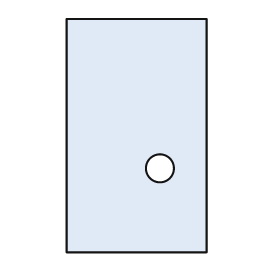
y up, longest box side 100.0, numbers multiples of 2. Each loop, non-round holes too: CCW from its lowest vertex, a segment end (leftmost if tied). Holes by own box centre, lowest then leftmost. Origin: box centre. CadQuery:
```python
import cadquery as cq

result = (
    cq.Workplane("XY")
    .moveTo(-30.0, -50.0)
    .lineTo(30.0, -50.0)
    .lineTo(30.0, 50.0)
    .lineTo(-30.0, 50.0)
    .close()
    .moveTo(10.0, -14.0)
    .circle(6.0)
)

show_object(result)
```